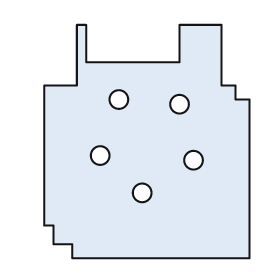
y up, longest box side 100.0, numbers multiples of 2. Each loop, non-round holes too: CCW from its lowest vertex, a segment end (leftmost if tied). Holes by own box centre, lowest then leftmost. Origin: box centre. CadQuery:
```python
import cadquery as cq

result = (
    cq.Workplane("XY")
    .moveTo(-32.0, -50.0)
    .lineTo(44.0, -50.0)
    .lineTo(44.0, 18.0)
    .lineTo(38.0, 18.0)
    .lineTo(38.0, 24.0)
    .lineTo(32.0, 24.0)
    .lineTo(32.0, 50.0)
    .lineTo(14.0, 50.0)
    .lineTo(14.0, 34.0)
    .lineTo(-26.0, 34.0)
    .lineTo(-26.0, 50.0)
    .lineTo(-30.0, 50.0)
    .lineTo(-30.0, 24.0)
    .lineTo(-44.0, 24.0)
    .lineTo(-44.0, -36.0)
    .lineTo(-40.0, -36.0)
    .lineTo(-40.0, -44.0)
    .lineTo(-32.0, -44.0)
    .close()
    .moveTo(-2.0, -22.0)
    .circle(4.0)
    .moveTo(20.0, -8.0)
    .circle(4.0)
    .moveTo(-20.0, -6.0)
    .circle(4.0)
    .moveTo(14.0, 16.0)
    .circle(4.0)
    .moveTo(-12.0, 18.0)
    .circle(4.0)
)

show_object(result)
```